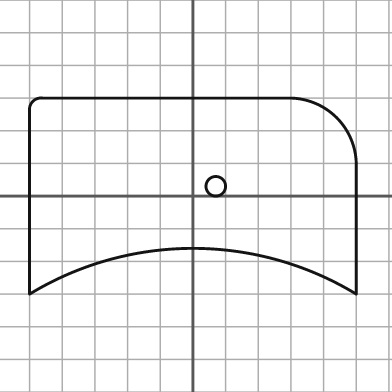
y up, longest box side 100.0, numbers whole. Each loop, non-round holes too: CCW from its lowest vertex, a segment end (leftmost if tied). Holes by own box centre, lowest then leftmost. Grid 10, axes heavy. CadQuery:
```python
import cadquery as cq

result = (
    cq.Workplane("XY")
    .moveTo(-50.0, -30.0)
    .threePointArc((0.0, -16.0), (50.0, -30.0))
    .lineTo(50.0, 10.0)
    .threePointArc((44.0, 24.0), (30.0, 30.0))
    .lineTo(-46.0, 30.0)
    .threePointArc((-49.0, 29.0), (-50.0, 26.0))
    .close()
    .moveTo(7.0, 3.0)
    .circle(3.0)
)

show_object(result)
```